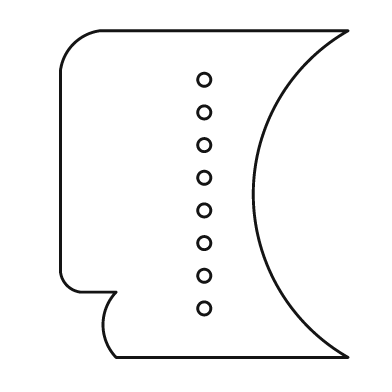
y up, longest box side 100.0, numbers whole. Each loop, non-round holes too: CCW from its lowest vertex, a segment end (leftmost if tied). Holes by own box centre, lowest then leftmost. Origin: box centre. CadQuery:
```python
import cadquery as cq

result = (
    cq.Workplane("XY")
    .moveTo(-27.0, -50.0)
    .lineTo(44.0, -50.0)
    .threePointArc((15.0, 0.0), (44.0, 50.0))
    .lineTo(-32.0, 50.0)
    .threePointArc((-40.0, 46.0), (-44.0, 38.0))
    .lineTo(-44.0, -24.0)
    .threePointArc((-42.0, -28.0), (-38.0, -30.0))
    .lineTo(-27.0, -30.0)
    .threePointArc((-31.0, -40.0), (-27.0, -50.0))
    .close()
    .moveTo(0.0, -35.0)
    .circle(2.0)
    .moveTo(0.0, -25.0)
    .circle(2.0)
    .moveTo(0.0, -15.0)
    .circle(2.0)
    .moveTo(0.0, -5.0)
    .circle(2.0)
    .moveTo(0.0, 5.0)
    .circle(2.0)
    .moveTo(0.0, 15.0)
    .circle(2.0)
    .moveTo(0.0, 25.0)
    .circle(2.0)
    .moveTo(0.0, 35.0)
    .circle(2.0)
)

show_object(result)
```